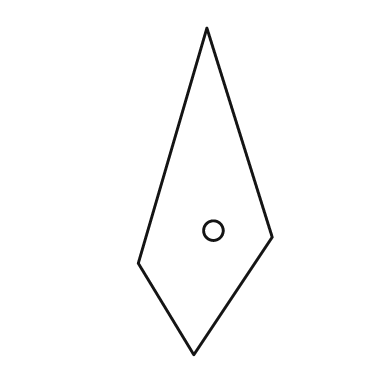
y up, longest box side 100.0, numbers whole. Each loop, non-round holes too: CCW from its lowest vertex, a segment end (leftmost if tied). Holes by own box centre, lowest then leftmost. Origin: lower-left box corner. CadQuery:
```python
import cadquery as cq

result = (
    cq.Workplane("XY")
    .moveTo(17.0, 0.0)
    .lineTo(41.0, 36.0)
    .lineTo(21.0, 100.0)
    .lineTo(0.0, 28.0)
    .close()
    .moveTo(23.0, 38.0)
    .circle(3.0)
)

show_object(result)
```